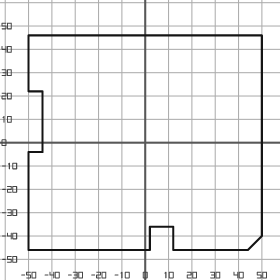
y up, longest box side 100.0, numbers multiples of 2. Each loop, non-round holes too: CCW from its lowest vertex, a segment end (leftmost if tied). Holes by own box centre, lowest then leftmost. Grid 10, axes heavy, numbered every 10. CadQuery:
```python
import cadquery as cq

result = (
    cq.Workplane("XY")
    .moveTo(-50.0, -46.0)
    .lineTo(2.0, -46.0)
    .lineTo(2.0, -36.0)
    .lineTo(12.0, -36.0)
    .lineTo(12.0, -46.0)
    .lineTo(44.0, -46.0)
    .lineTo(50.0, -40.0)
    .lineTo(50.0, 46.0)
    .lineTo(-50.0, 46.0)
    .lineTo(-50.0, 22.0)
    .lineTo(-44.0, 22.0)
    .lineTo(-44.0, -4.0)
    .lineTo(-50.0, -4.0)
    .close()
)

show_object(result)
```